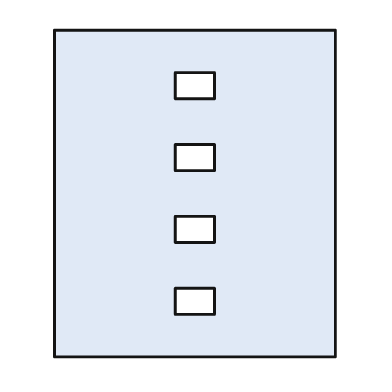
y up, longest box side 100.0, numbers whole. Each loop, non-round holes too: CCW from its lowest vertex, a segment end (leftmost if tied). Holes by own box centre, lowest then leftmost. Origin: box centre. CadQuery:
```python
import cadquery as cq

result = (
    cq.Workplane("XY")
    .moveTo(-43.0, -50.0)
    .lineTo(43.0, -50.0)
    .lineTo(43.0, 50.0)
    .lineTo(-43.0, 50.0)
    .close()
    .moveTo(-6.0, -37.0)
    .lineTo(6.0, -37.0)
    .lineTo(6.0, -29.0)
    .lineTo(-6.0, -29.0)
    .close()
    .moveTo(-6.0, -15.0)
    .lineTo(6.0, -15.0)
    .lineTo(6.0, -7.0)
    .lineTo(-6.0, -7.0)
    .close()
    .moveTo(-6.0, 7.0)
    .lineTo(6.0, 7.0)
    .lineTo(6.0, 15.0)
    .lineTo(-6.0, 15.0)
    .close()
    .moveTo(-6.0, 29.0)
    .lineTo(6.0, 29.0)
    .lineTo(6.0, 37.0)
    .lineTo(-6.0, 37.0)
    .close()
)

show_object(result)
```